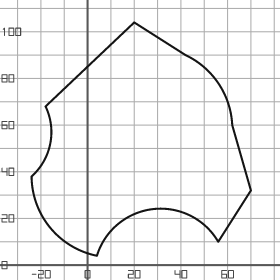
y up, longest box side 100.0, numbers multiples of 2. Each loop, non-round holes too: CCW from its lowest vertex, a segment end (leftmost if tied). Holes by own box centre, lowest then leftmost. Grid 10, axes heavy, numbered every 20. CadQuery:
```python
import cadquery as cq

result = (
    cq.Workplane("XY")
    .moveTo(4.0, 4.0)
    .threePointArc((28.0, 24.0), (56.0, 10.0))
    .lineTo(70.0, 32.0)
    .lineTo(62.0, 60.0)
    .threePointArc((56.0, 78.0), (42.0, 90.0))
    .lineTo(20.0, 104.0)
    .lineTo(-18.0, 68.0)
    .threePointArc((-16.0, 52.0), (-24.0, 38.0))
    .threePointArc((-16.0, 16.0), (4.0, 4.0))
    .close()
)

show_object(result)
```